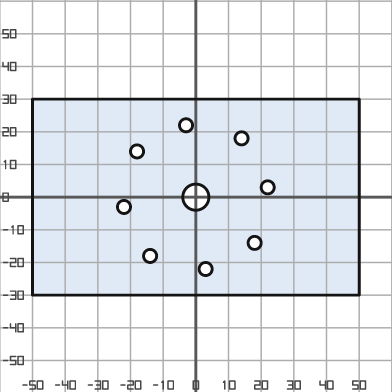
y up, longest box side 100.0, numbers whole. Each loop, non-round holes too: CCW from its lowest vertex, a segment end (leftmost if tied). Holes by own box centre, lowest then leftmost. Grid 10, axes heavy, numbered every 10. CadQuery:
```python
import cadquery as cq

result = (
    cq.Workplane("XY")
    .moveTo(-50.0, -30.0)
    .lineTo(50.0, -30.0)
    .lineTo(50.0, 30.0)
    .lineTo(-50.0, 30.0)
    .close()
    .moveTo(3.0, -22.0)
    .circle(2.0)
    .moveTo(-14.0, -18.0)
    .circle(2.0)
    .moveTo(18.0, -14.0)
    .circle(2.0)
    .moveTo(-22.0, -3.0)
    .circle(2.0)
    .moveTo(0.0, 0.0)
    .circle(4.0)
    .moveTo(22.0, 3.0)
    .circle(2.0)
    .moveTo(-18.0, 14.0)
    .circle(2.0)
    .moveTo(14.0, 18.0)
    .circle(2.0)
    .moveTo(-3.0, 22.0)
    .circle(2.0)
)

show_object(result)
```